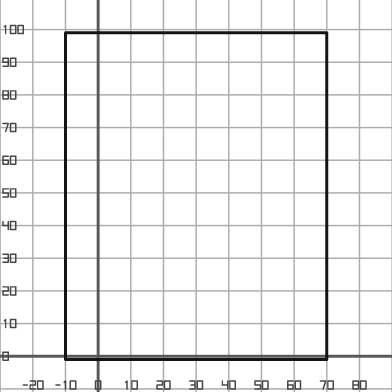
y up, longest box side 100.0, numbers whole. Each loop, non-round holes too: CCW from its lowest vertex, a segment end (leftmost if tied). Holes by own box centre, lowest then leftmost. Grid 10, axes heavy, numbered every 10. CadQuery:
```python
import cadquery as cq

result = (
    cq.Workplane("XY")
    .moveTo(-10.0, -1.0)
    .lineTo(70.0, -1.0)
    .lineTo(70.0, 99.0)
    .lineTo(-10.0, 99.0)
    .close()
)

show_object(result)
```